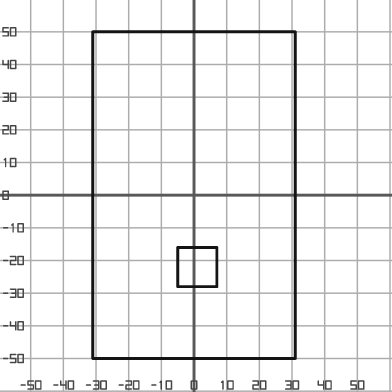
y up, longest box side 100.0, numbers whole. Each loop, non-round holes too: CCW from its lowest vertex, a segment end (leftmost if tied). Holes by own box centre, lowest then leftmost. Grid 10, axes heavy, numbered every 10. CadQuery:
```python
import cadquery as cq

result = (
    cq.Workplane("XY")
    .moveTo(-31.0, -50.0)
    .lineTo(31.0, -50.0)
    .lineTo(31.0, 50.0)
    .lineTo(-31.0, 50.0)
    .close()
    .moveTo(-5.0, -28.0)
    .lineTo(7.0, -28.0)
    .lineTo(7.0, -16.0)
    .lineTo(-5.0, -16.0)
    .close()
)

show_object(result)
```